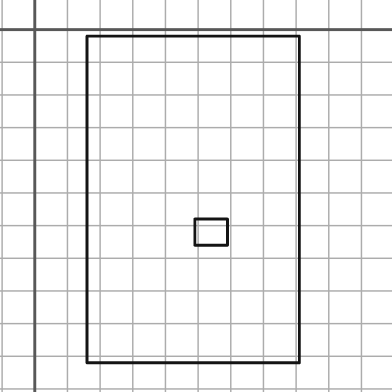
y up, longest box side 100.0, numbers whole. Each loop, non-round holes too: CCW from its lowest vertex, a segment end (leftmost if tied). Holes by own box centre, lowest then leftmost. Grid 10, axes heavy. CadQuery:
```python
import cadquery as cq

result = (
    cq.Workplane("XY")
    .moveTo(16.0, -102.0)
    .lineTo(81.0, -102.0)
    .lineTo(81.0, -2.0)
    .lineTo(16.0, -2.0)
    .close()
    .moveTo(49.0, -66.0)
    .lineTo(59.0, -66.0)
    .lineTo(59.0, -58.0)
    .lineTo(49.0, -58.0)
    .close()
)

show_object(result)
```